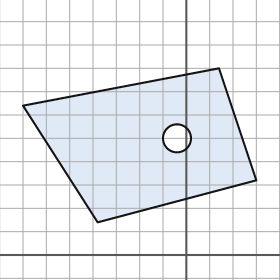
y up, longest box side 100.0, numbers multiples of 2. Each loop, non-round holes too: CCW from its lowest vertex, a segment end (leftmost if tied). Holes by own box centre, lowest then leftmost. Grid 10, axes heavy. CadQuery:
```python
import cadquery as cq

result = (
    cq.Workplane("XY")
    .moveTo(-38.0, 14.0)
    .lineTo(30.0, 32.0)
    .lineTo(14.0, 80.0)
    .lineTo(-70.0, 64.0)
    .close()
    .moveTo(-4.0, 50.0)
    .circle(6.0)
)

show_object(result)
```